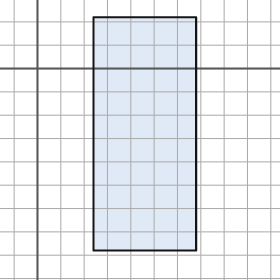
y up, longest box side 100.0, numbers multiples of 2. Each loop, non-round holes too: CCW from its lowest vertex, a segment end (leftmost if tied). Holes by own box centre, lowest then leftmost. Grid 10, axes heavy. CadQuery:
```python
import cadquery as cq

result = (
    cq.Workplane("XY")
    .moveTo(24.0, -78.0)
    .lineTo(68.0, -78.0)
    .lineTo(68.0, 22.0)
    .lineTo(24.0, 22.0)
    .close()
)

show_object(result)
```